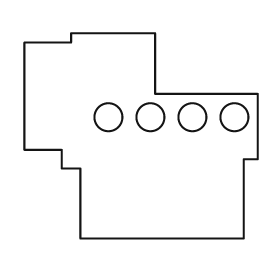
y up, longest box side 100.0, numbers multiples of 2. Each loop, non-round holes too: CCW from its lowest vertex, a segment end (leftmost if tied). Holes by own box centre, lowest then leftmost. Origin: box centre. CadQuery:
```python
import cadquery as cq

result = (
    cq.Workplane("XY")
    .moveTo(-26.0, -44.0)
    .lineTo(44.0, -44.0)
    .lineTo(44.0, -10.0)
    .lineTo(50.0, -10.0)
    .lineTo(50.0, 18.0)
    .lineTo(6.0, 18.0)
    .lineTo(6.0, 44.0)
    .lineTo(-30.0, 44.0)
    .lineTo(-30.0, 40.0)
    .lineTo(-50.0, 40.0)
    .lineTo(-50.0, -6.0)
    .lineTo(-34.0, -6.0)
    .lineTo(-34.0, -14.0)
    .lineTo(-26.0, -14.0)
    .close()
    .moveTo(-14.0, 8.0)
    .circle(6.0)
    .moveTo(4.0, 8.0)
    .circle(6.0)
    .moveTo(22.0, 8.0)
    .circle(6.0)
    .moveTo(40.0, 8.0)
    .circle(6.0)
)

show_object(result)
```